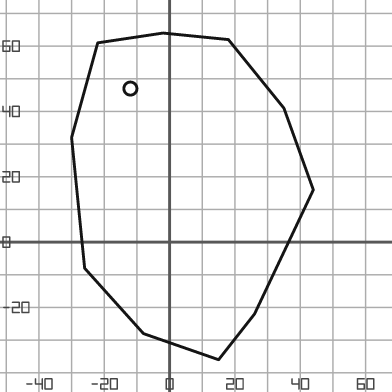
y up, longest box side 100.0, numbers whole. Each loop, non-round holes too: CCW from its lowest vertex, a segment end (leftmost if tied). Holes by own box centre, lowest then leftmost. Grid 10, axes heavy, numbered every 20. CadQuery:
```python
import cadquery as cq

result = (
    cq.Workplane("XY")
    .moveTo(15.0, -36.0)
    .lineTo(26.0, -22.0)
    .lineTo(44.0, 16.0)
    .lineTo(35.0, 41.0)
    .lineTo(18.0, 62.0)
    .lineTo(-2.0, 64.0)
    .lineTo(-22.0, 61.0)
    .lineTo(-30.0, 32.0)
    .lineTo(-26.0, -8.0)
    .lineTo(-8.0, -28.0)
    .close()
    .moveTo(-12.0, 47.0)
    .circle(2.0)
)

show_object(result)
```